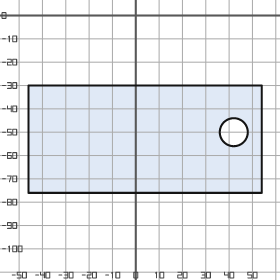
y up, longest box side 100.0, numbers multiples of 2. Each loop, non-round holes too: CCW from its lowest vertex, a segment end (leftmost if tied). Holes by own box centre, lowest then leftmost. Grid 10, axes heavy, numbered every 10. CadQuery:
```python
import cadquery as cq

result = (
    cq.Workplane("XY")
    .moveTo(-46.0, -76.0)
    .lineTo(54.0, -76.0)
    .lineTo(54.0, -30.0)
    .lineTo(-46.0, -30.0)
    .close()
    .moveTo(42.0, -50.0)
    .circle(6.0)
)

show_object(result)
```